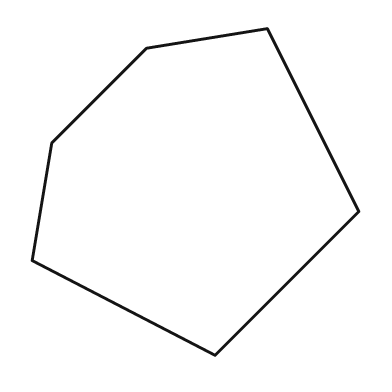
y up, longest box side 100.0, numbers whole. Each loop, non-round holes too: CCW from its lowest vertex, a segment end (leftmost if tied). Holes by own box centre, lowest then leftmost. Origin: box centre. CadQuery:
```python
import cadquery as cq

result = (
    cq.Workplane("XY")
    .moveTo(6.0, -50.0)
    .lineTo(50.0, -6.0)
    .lineTo(22.0, 50.0)
    .lineTo(-15.0, 44.0)
    .lineTo(-44.0, 15.0)
    .lineTo(-50.0, -21.0)
    .close()
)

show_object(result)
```